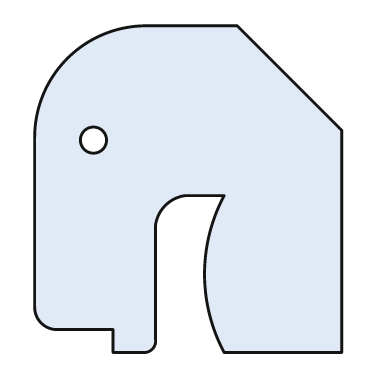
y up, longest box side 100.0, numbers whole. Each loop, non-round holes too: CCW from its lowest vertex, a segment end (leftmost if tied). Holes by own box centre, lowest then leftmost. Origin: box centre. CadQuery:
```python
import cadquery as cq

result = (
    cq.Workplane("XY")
    .moveTo(-23.0, -50.0)
    .lineTo(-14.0, -50.0)
    .threePointArc((-11.0, -49.0), (-10.0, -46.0))
    .lineTo(-10.0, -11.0)
    .threePointArc((-7.0, -5.0), (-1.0, -2.0))
    .lineTo(11.0, -2.0)
    .threePointArc((5.0, -26.0), (11.0, -50.0))
    .lineTo(47.0, -50.0)
    .lineTo(47.0, 18.0)
    .lineTo(15.0, 50.0)
    .lineTo(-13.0, 50.0)
    .threePointArc((-37.0, 40.0), (-47.0, 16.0))
    .lineTo(-47.0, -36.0)
    .threePointArc((-45.0, -41.0), (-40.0, -43.0))
    .lineTo(-23.0, -43.0)
    .close()
    .moveTo(-29.0, 15.0)
    .circle(4.0)
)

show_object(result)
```